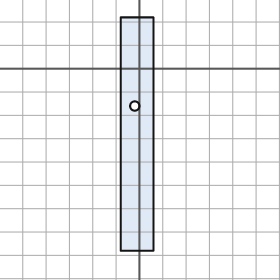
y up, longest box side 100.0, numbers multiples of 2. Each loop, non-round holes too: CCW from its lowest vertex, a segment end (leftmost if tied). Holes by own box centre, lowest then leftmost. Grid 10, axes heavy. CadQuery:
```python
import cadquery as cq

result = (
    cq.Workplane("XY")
    .moveTo(-8.0, -78.0)
    .lineTo(6.0, -78.0)
    .lineTo(6.0, 22.0)
    .lineTo(-8.0, 22.0)
    .close()
    .moveTo(-2.0, -16.0)
    .circle(2.0)
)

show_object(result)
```